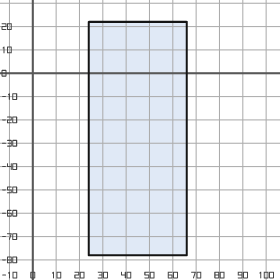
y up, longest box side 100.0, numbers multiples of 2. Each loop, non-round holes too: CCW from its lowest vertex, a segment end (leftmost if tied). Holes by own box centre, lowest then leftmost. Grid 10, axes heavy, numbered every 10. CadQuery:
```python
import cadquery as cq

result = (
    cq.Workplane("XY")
    .moveTo(24.0, -78.0)
    .lineTo(66.0, -78.0)
    .lineTo(66.0, 22.0)
    .lineTo(24.0, 22.0)
    .close()
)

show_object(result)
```